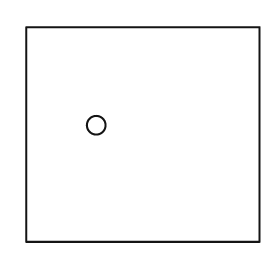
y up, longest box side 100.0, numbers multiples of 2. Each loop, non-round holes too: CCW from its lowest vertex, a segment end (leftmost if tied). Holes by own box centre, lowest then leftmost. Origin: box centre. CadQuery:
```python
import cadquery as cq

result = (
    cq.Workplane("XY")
    .moveTo(-50.0, -46.0)
    .lineTo(50.0, -46.0)
    .lineTo(50.0, 46.0)
    .lineTo(-50.0, 46.0)
    .close()
    .moveTo(-20.0, 4.0)
    .circle(4.0)
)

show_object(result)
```